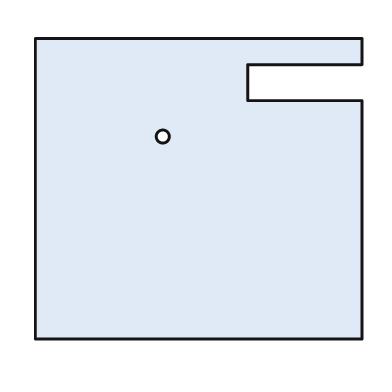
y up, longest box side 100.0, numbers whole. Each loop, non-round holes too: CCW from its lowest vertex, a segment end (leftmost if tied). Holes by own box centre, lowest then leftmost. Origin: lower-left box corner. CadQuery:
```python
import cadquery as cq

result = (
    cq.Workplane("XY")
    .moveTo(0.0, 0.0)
    .lineTo(100.0, 0.0)
    .lineTo(100.0, 73.0)
    .lineTo(65.0, 73.0)
    .lineTo(65.0, 84.0)
    .lineTo(100.0, 84.0)
    .lineTo(100.0, 92.0)
    .lineTo(0.0, 92.0)
    .close()
    .moveTo(39.0, 62.0)
    .circle(2.0)
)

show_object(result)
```